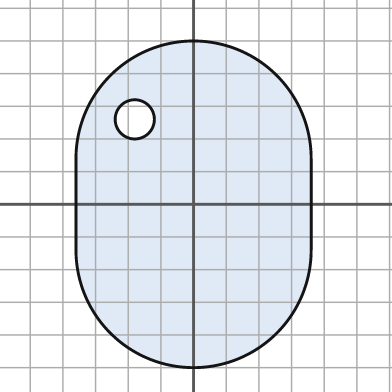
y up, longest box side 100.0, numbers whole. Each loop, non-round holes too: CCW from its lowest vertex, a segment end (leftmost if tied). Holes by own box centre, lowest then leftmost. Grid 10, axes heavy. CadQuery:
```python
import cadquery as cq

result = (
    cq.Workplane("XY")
    .moveTo(-36.0, -14.0)
    .threePointArc((0.0, -50.0), (36.0, -14.0))
    .lineTo(36.0, 14.0)
    .threePointArc((0.0, 50.0), (-36.0, 14.0))
    .close()
    .moveTo(-18.0, 26.0)
    .circle(6.0)
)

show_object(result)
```